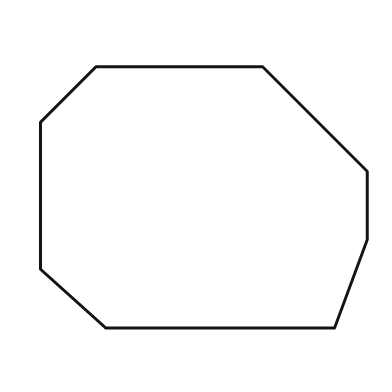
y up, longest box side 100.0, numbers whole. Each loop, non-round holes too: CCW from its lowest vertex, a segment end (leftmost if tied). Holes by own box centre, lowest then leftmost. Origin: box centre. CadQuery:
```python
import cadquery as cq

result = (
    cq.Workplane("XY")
    .moveTo(-30.0, -40.0)
    .lineTo(40.0, -40.0)
    .lineTo(50.0, -13.0)
    .lineTo(50.0, 8.0)
    .lineTo(18.0, 40.0)
    .lineTo(-33.0, 40.0)
    .lineTo(-50.0, 23.0)
    .lineTo(-50.0, -22.0)
    .close()
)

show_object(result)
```